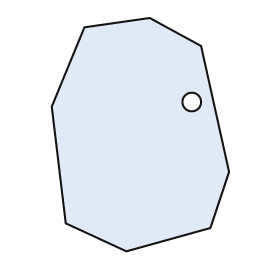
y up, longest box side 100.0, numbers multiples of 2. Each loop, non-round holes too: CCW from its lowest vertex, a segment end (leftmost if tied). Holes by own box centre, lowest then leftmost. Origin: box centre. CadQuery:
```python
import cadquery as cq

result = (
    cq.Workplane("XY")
    .moveTo(-6.0, -50.0)
    .lineTo(30.0, -40.0)
    .lineTo(38.0, -16.0)
    .lineTo(26.0, 38.0)
    .lineTo(4.0, 50.0)
    .lineTo(-24.0, 46.0)
    .lineTo(-38.0, 12.0)
    .lineTo(-32.0, -38.0)
    .close()
    .moveTo(22.0, 14.0)
    .circle(4.0)
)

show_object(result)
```